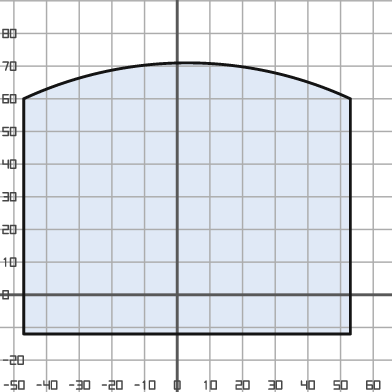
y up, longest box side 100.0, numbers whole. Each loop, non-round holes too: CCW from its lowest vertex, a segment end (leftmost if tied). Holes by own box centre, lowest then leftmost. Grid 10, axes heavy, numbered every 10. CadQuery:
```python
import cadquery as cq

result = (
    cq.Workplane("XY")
    .moveTo(-47.0, -12.0)
    .lineTo(53.0, -12.0)
    .lineTo(53.0, 60.0)
    .threePointArc((3.0, 71.0), (-47.0, 60.0))
    .close()
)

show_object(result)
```